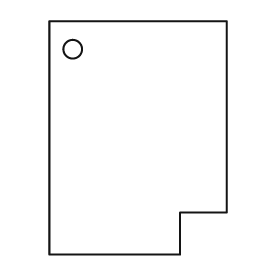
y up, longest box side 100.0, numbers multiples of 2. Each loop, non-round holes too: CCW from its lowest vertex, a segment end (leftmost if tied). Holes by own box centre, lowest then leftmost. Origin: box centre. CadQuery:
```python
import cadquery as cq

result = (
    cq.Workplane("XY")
    .moveTo(-38.0, -50.0)
    .lineTo(18.0, -50.0)
    .lineTo(18.0, -32.0)
    .lineTo(38.0, -32.0)
    .lineTo(38.0, 50.0)
    .lineTo(-38.0, 50.0)
    .close()
    .moveTo(-28.0, 38.0)
    .circle(4.0)
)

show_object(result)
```